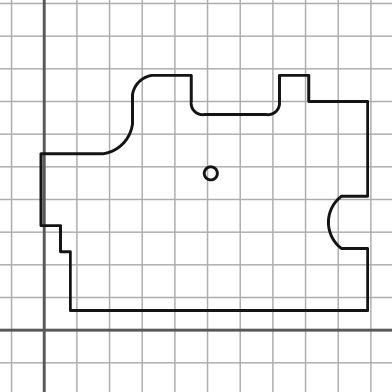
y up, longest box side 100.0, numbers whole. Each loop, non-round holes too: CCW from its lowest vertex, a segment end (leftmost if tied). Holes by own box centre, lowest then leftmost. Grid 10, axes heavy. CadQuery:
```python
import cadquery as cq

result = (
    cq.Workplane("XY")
    .moveTo(8.0, 6.0)
    .lineTo(99.0, 6.0)
    .lineTo(99.0, 25.0)
    .lineTo(91.0, 25.0)
    .threePointArc((87.0, 33.0), (91.0, 41.0))
    .lineTo(99.0, 41.0)
    .lineTo(99.0, 70.0)
    .lineTo(81.0, 70.0)
    .lineTo(81.0, 78.0)
    .lineTo(72.0, 78.0)
    .lineTo(72.0, 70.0)
    .threePointArc((71.0, 67.0), (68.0, 66.0))
    .lineTo(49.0, 66.0)
    .threePointArc((46.0, 67.0), (45.0, 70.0))
    .lineTo(45.0, 78.0)
    .lineTo(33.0, 78.0)
    .threePointArc((29.0, 76.0), (27.0, 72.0))
    .lineTo(27.0, 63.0)
    .threePointArc((24.0, 57.0), (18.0, 54.0))
    .lineTo(-1.0, 54.0)
    .lineTo(-1.0, 32.0)
    .lineTo(5.0, 32.0)
    .lineTo(5.0, 24.0)
    .lineTo(8.0, 24.0)
    .close()
    .moveTo(51.0, 48.0)
    .circle(2.0)
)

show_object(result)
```